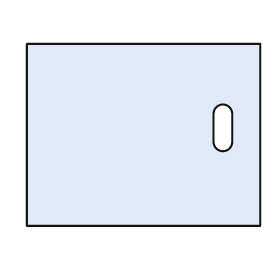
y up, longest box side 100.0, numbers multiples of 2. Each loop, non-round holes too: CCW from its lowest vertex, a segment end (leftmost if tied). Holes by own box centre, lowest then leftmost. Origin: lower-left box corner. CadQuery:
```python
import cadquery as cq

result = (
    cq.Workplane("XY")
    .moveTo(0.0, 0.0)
    .lineTo(100.0, 0.0)
    .lineTo(100.0, 78.0)
    .lineTo(0.0, 78.0)
    .close()
    .moveTo(80.0, 36.0)
    .threePointArc((84.0, 32.0), (88.0, 36.0))
    .lineTo(88.0, 48.0)
    .threePointArc((84.0, 52.0), (80.0, 48.0))
    .close()
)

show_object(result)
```